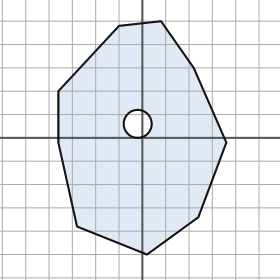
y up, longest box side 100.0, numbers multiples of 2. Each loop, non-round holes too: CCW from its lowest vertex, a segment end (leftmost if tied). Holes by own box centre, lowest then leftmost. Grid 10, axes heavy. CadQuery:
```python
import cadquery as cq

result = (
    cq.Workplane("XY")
    .moveTo(2.0, -50.0)
    .lineTo(24.0, -34.0)
    .lineTo(36.0, -2.0)
    .lineTo(22.0, 30.0)
    .lineTo(8.0, 50.0)
    .lineTo(-10.0, 48.0)
    .lineTo(-36.0, 20.0)
    .lineTo(-36.0, -2.0)
    .lineTo(-28.0, -38.0)
    .close()
    .moveTo(-2.0, 6.0)
    .circle(6.0)
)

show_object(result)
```